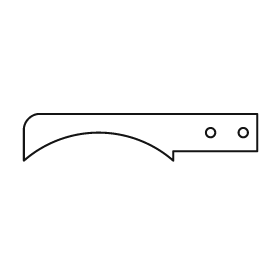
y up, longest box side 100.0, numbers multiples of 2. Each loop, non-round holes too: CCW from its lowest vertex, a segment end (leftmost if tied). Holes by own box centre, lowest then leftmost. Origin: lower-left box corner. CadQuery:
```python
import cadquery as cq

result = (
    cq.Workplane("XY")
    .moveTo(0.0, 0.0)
    .threePointArc((32.0, 12.0), (64.0, 0.0))
    .lineTo(64.0, 4.0)
    .lineTo(100.0, 4.0)
    .lineTo(100.0, 20.0)
    .lineTo(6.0, 20.0)
    .threePointArc((2.0, 18.0), (0.0, 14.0))
    .close()
    .moveTo(80.0, 12.0)
    .circle(2.0)
    .moveTo(94.0, 12.0)
    .circle(2.0)
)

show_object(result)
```